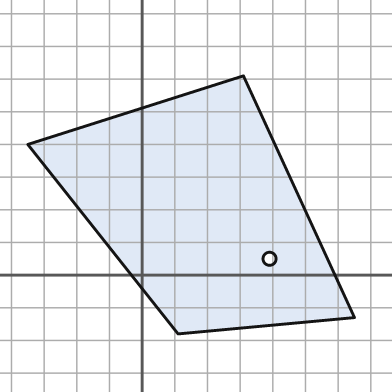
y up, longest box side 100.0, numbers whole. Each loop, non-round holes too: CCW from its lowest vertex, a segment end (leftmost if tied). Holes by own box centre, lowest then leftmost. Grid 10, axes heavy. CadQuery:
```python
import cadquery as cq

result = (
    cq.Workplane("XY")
    .moveTo(11.0, -18.0)
    .lineTo(65.0, -13.0)
    .lineTo(31.0, 61.0)
    .lineTo(-35.0, 40.0)
    .close()
    .moveTo(39.0, 5.0)
    .circle(2.0)
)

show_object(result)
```